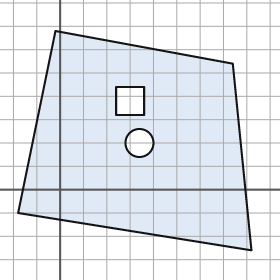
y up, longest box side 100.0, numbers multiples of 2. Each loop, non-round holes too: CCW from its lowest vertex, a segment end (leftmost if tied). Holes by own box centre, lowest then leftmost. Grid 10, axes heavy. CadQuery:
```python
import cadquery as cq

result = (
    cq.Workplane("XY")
    .moveTo(82.0, -26.0)
    .lineTo(74.0, 54.0)
    .lineTo(-2.0, 68.0)
    .lineTo(-18.0, -10.0)
    .close()
    .moveTo(34.0, 20.0)
    .circle(6.0)
    .moveTo(24.0, 32.0)
    .lineTo(36.0, 32.0)
    .lineTo(36.0, 44.0)
    .lineTo(24.0, 44.0)
    .close()
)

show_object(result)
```